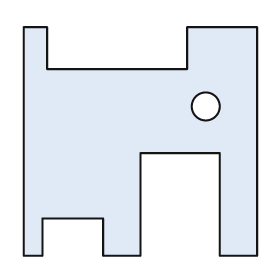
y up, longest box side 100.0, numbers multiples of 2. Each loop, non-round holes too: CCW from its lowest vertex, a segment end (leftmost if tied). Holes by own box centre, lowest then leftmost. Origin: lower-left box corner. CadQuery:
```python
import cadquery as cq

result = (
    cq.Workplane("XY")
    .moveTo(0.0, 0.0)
    .lineTo(8.0, 0.0)
    .lineTo(8.0, 16.0)
    .lineTo(34.0, 16.0)
    .lineTo(34.0, 0.0)
    .lineTo(50.0, 0.0)
    .lineTo(50.0, 44.0)
    .lineTo(84.0, 44.0)
    .lineTo(84.0, 0.0)
    .lineTo(100.0, 0.0)
    .lineTo(100.0, 98.0)
    .lineTo(70.0, 98.0)
    .lineTo(70.0, 80.0)
    .lineTo(10.0, 80.0)
    .lineTo(10.0, 98.0)
    .lineTo(0.0, 98.0)
    .close()
    .moveTo(78.0, 64.0)
    .circle(6.0)
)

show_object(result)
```